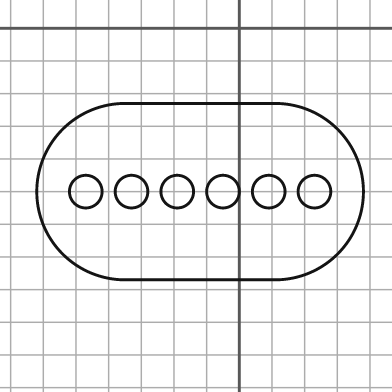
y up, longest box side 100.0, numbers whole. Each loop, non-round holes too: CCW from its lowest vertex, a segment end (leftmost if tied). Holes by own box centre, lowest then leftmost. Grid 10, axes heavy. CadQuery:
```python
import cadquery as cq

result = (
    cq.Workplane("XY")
    .moveTo(-35.0, -77.0)
    .lineTo(11.0, -77.0)
    .threePointArc((38.0, -50.0), (11.0, -23.0))
    .lineTo(-35.0, -23.0)
    .threePointArc((-62.0, -50.0), (-35.0, -77.0))
    .close()
    .moveTo(-47.0, -50.0)
    .circle(5.0)
    .moveTo(-33.0, -50.0)
    .circle(5.0)
    .moveTo(-19.0, -50.0)
    .circle(5.0)
    .moveTo(-5.0, -50.0)
    .circle(5.0)
    .moveTo(9.0, -50.0)
    .circle(5.0)
    .moveTo(23.0, -50.0)
    .circle(5.0)
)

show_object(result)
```